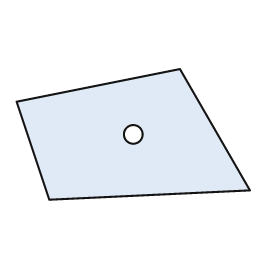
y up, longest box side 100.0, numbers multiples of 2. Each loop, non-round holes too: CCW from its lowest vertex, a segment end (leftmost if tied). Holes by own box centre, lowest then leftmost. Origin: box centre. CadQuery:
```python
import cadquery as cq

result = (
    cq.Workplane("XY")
    .moveTo(-36.0, -28.0)
    .lineTo(50.0, -24.0)
    .lineTo(20.0, 28.0)
    .lineTo(-50.0, 14.0)
    .close()
    .moveTo(0.0, 0.0)
    .circle(4.0)
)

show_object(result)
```